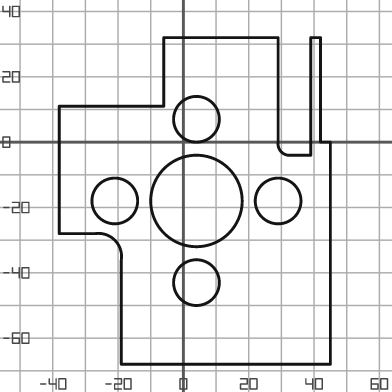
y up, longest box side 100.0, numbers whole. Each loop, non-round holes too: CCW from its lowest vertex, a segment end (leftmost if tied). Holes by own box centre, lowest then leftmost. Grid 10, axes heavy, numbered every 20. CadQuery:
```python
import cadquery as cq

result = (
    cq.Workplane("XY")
    .moveTo(-19.0, -68.0)
    .lineTo(45.0, -68.0)
    .lineTo(45.0, 0.0)
    .lineTo(42.0, 0.0)
    .lineTo(42.0, 32.0)
    .lineTo(39.0, 32.0)
    .lineTo(39.0, -4.0)
    .lineTo(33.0, -4.0)
    .threePointArc((30.0, -3.0), (29.0, 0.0))
    .lineTo(29.0, 32.0)
    .lineTo(-6.0, 32.0)
    .lineTo(-6.0, 11.0)
    .lineTo(-38.0, 11.0)
    .lineTo(-38.0, -28.0)
    .lineTo(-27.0, -28.0)
    .threePointArc((-21.0, -30.0), (-19.0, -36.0))
    .close()
    .moveTo(4.0, -43.0)
    .circle(7.0)
    .moveTo(-21.0, -18.0)
    .circle(7.0)
    .moveTo(4.0, -18.0)
    .circle(14.0)
    .moveTo(29.0, -18.0)
    .circle(7.0)
    .moveTo(4.0, 7.0)
    .circle(7.0)
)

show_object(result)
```